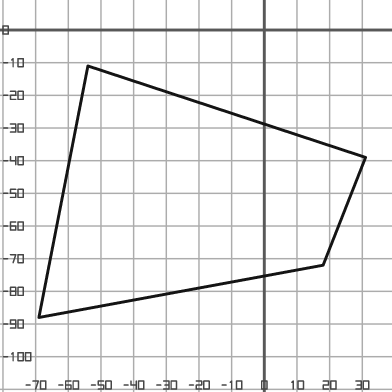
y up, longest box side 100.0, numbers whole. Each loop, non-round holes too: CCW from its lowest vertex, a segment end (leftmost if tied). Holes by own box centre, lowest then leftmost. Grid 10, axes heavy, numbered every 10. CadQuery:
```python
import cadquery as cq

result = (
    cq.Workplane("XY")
    .moveTo(-69.0, -88.0)
    .lineTo(18.0, -72.0)
    .lineTo(31.0, -39.0)
    .lineTo(-54.0, -11.0)
    .close()
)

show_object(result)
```